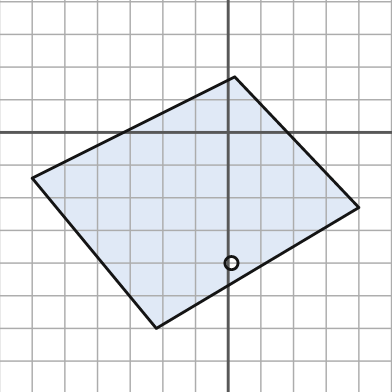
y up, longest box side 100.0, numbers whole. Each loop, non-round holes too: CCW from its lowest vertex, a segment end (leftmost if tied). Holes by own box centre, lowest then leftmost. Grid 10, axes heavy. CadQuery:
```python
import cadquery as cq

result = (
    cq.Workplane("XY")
    .moveTo(-22.0, -60.0)
    .lineTo(40.0, -23.0)
    .lineTo(2.0, 17.0)
    .lineTo(-60.0, -14.0)
    .close()
    .moveTo(1.0, -40.0)
    .circle(2.0)
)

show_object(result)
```